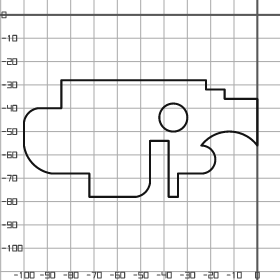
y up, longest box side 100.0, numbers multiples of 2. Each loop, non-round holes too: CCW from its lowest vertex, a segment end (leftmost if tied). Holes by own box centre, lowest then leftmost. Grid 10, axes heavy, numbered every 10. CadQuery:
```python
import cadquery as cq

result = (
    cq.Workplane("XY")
    .moveTo(-72.0, -78.0)
    .lineTo(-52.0, -78.0)
    .threePointArc((-48.0, -76.0), (-46.0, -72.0))
    .lineTo(-46.0, -54.0)
    .lineTo(-38.0, -54.0)
    .lineTo(-38.0, -78.0)
    .lineTo(-34.0, -78.0)
    .lineTo(-34.0, -68.0)
    .lineTo(-24.0, -68.0)
    .threePointArc((-18.0, -62.0), (-24.0, -56.0))
    .threePointArc((-12.0, -50.0), (0.0, -56.0))
    .lineTo(0.0, -36.0)
    .lineTo(-14.0, -36.0)
    .lineTo(-14.0, -32.0)
    .lineTo(-22.0, -32.0)
    .lineTo(-22.0, -28.0)
    .lineTo(-84.0, -28.0)
    .lineTo(-84.0, -40.0)
    .lineTo(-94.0, -40.0)
    .threePointArc((-98.0, -42.0), (-100.0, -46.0))
    .lineTo(-100.0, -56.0)
    .threePointArc((-96.0, -64.0), (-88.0, -68.0))
    .lineTo(-72.0, -68.0)
    .close()
    .moveTo(-36.0, -44.0)
    .circle(6.0)
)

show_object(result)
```